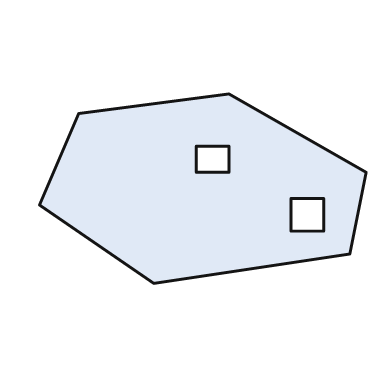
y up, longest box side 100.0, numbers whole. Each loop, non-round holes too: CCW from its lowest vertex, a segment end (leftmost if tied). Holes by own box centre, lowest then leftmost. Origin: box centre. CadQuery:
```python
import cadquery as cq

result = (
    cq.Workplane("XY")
    .moveTo(-15.0, -29.0)
    .lineTo(45.0, -20.0)
    .lineTo(50.0, 5.0)
    .lineTo(8.0, 29.0)
    .lineTo(-38.0, 23.0)
    .lineTo(-50.0, -5.0)
    .close()
    .moveTo(27.0, -13.0)
    .lineTo(37.0, -13.0)
    .lineTo(37.0, -3.0)
    .lineTo(27.0, -3.0)
    .close()
    .moveTo(-2.0, 5.0)
    .lineTo(8.0, 5.0)
    .lineTo(8.0, 13.0)
    .lineTo(-2.0, 13.0)
    .close()
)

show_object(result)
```